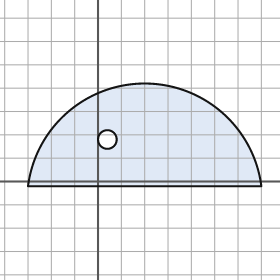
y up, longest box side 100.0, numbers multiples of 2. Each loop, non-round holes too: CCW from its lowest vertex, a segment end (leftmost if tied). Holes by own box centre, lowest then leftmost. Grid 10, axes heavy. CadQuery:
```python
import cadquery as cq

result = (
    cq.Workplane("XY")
    .moveTo(-30.0, -2.0)
    .lineTo(70.0, -2.0)
    .threePointArc((20.0, 42.0), (-30.0, -2.0))
    .close()
    .moveTo(4.0, 18.0)
    .circle(4.0)
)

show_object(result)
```